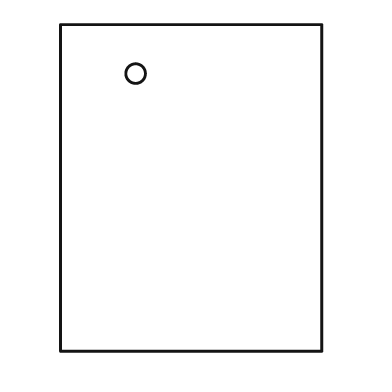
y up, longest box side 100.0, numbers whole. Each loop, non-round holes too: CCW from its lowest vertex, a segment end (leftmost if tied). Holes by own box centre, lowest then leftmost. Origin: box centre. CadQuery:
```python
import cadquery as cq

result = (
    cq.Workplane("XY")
    .moveTo(-40.0, -50.0)
    .lineTo(40.0, -50.0)
    .lineTo(40.0, 50.0)
    .lineTo(-40.0, 50.0)
    .close()
    .moveTo(-17.0, 35.0)
    .circle(3.0)
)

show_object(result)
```